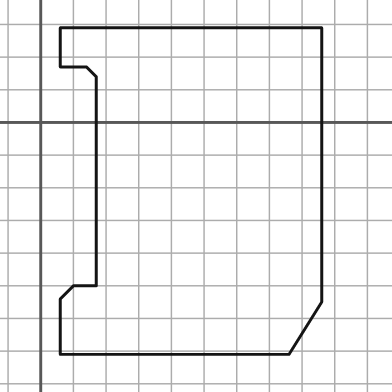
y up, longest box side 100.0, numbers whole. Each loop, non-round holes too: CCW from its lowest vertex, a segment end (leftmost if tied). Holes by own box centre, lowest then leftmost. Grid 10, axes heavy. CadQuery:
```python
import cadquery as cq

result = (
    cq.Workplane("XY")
    .moveTo(6.0, -71.0)
    .lineTo(76.0, -71.0)
    .lineTo(86.0, -55.0)
    .lineTo(86.0, 29.0)
    .lineTo(6.0, 29.0)
    .lineTo(6.0, 17.0)
    .lineTo(14.0, 17.0)
    .lineTo(17.0, 14.0)
    .lineTo(17.0, -50.0)
    .lineTo(10.0, -50.0)
    .lineTo(6.0, -54.0)
    .close()
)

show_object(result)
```